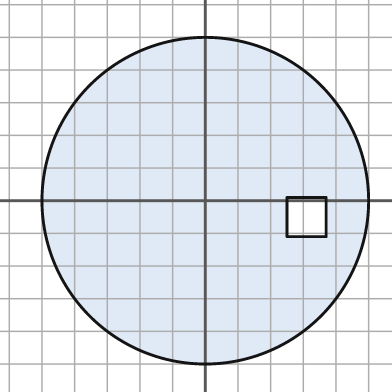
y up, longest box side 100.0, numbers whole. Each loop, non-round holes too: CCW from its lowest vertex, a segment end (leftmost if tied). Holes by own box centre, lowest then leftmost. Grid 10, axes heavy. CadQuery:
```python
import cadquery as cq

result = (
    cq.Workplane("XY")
    .moveTo(0.0, 0.0)
    .circle(50.0)
    .moveTo(25.0, -11.0)
    .lineTo(37.0, -11.0)
    .lineTo(37.0, 1.0)
    .lineTo(25.0, 1.0)
    .close()
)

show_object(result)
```